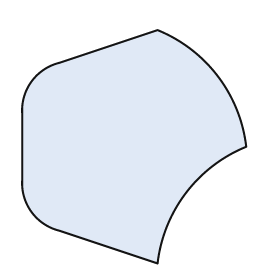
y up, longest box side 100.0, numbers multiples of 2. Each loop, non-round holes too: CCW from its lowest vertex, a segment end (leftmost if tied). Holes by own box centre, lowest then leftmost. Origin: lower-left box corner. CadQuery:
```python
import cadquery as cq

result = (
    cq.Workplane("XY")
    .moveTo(58.0, 0.0)
    .threePointArc((70.0, 30.0), (96.0, 50.0))
    .threePointArc((84.0, 80.0), (58.0, 100.0))
    .lineTo(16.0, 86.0)
    .threePointArc((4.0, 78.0), (0.0, 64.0))
    .lineTo(0.0, 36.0)
    .threePointArc((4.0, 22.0), (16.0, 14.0))
    .close()
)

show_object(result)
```